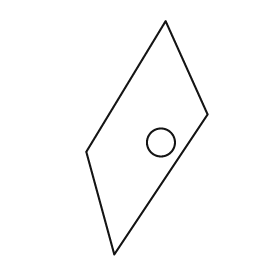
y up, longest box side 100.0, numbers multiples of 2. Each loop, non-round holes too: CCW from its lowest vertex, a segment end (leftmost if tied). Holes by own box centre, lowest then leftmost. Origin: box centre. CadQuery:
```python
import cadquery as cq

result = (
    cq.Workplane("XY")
    .moveTo(-14.0, -50.0)
    .lineTo(26.0, 10.0)
    .lineTo(8.0, 50.0)
    .lineTo(-26.0, -6.0)
    .close()
    .moveTo(6.0, -2.0)
    .circle(6.0)
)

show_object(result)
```